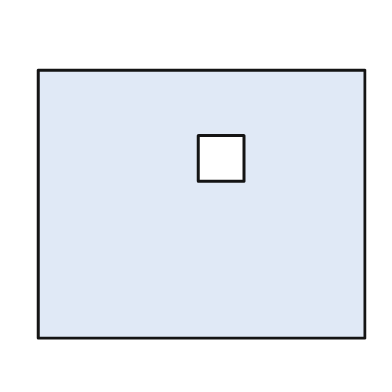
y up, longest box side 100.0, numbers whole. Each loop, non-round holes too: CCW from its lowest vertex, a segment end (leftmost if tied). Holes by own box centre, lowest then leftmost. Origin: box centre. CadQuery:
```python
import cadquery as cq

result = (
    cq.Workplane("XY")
    .moveTo(-50.0, -41.0)
    .lineTo(50.0, -41.0)
    .lineTo(50.0, 41.0)
    .lineTo(-50.0, 41.0)
    .close()
    .moveTo(-1.0, 7.0)
    .lineTo(13.0, 7.0)
    .lineTo(13.0, 21.0)
    .lineTo(-1.0, 21.0)
    .close()
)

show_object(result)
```